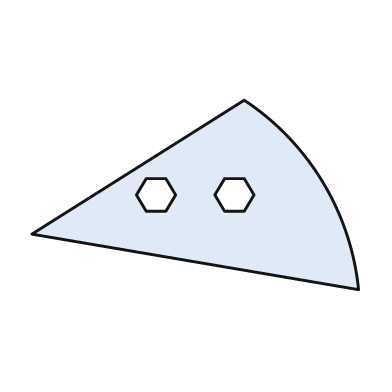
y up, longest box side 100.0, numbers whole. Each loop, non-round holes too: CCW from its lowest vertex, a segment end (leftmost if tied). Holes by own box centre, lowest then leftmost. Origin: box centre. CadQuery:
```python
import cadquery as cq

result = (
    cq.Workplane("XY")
    .moveTo(50.0, -29.0)
    .threePointArc((39.0, 4.0), (15.0, 29.0))
    .lineTo(-50.0, -12.0)
    .close()
    .moveTo(-15.0, -5.0)
    .lineTo(-9.0, -5.0)
    .lineTo(-6.0, 0.0)
    .lineTo(-9.0, 5.0)
    .lineTo(-15.0, 5.0)
    .lineTo(-18.0, 0.0)
    .close()
    .moveTo(9.0, -5.0)
    .lineTo(15.0, -5.0)
    .lineTo(18.0, 0.0)
    .lineTo(15.0, 5.0)
    .lineTo(9.0, 5.0)
    .lineTo(6.0, 0.0)
    .close()
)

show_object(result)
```